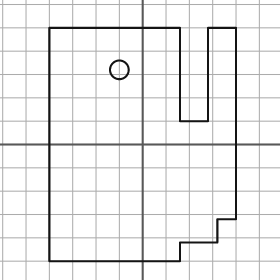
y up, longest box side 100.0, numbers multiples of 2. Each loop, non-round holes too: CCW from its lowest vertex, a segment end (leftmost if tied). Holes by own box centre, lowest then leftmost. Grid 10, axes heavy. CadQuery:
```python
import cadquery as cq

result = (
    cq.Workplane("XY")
    .moveTo(-40.0, -50.0)
    .lineTo(16.0, -50.0)
    .lineTo(16.0, -42.0)
    .lineTo(32.0, -42.0)
    .lineTo(32.0, -32.0)
    .lineTo(40.0, -32.0)
    .lineTo(40.0, 50.0)
    .lineTo(28.0, 50.0)
    .lineTo(28.0, 10.0)
    .lineTo(16.0, 10.0)
    .lineTo(16.0, 50.0)
    .lineTo(-40.0, 50.0)
    .close()
    .moveTo(-10.0, 32.0)
    .circle(4.0)
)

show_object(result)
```